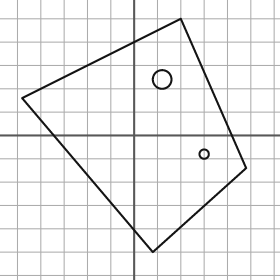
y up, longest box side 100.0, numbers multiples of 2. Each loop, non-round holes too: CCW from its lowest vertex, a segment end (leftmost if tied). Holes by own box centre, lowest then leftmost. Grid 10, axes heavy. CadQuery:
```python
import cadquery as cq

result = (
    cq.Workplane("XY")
    .moveTo(8.0, -50.0)
    .lineTo(48.0, -14.0)
    .lineTo(20.0, 50.0)
    .lineTo(-48.0, 16.0)
    .close()
    .moveTo(30.0, -8.0)
    .circle(2.0)
    .moveTo(12.0, 24.0)
    .circle(4.0)
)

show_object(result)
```